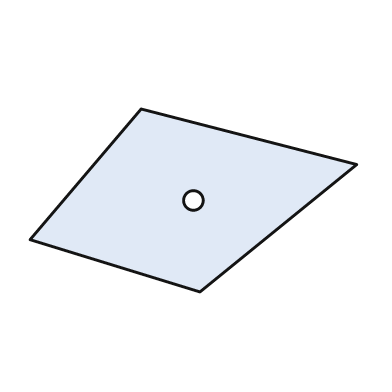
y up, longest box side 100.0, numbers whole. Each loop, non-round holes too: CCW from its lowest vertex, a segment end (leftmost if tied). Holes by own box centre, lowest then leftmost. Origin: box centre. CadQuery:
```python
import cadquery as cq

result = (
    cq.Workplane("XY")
    .moveTo(2.0, -28.0)
    .lineTo(50.0, 11.0)
    .lineTo(-16.0, 28.0)
    .lineTo(-50.0, -12.0)
    .close()
    .moveTo(0.0, 0.0)
    .circle(3.0)
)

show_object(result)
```